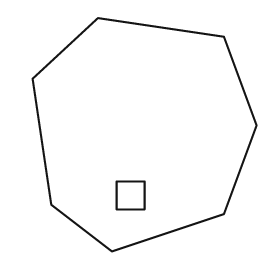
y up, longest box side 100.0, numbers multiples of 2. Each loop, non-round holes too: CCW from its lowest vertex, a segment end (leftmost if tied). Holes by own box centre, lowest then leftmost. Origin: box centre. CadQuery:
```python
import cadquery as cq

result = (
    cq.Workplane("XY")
    .moveTo(-14.0, -50.0)
    .lineTo(34.0, -34.0)
    .lineTo(48.0, 4.0)
    .lineTo(34.0, 42.0)
    .lineTo(-20.0, 50.0)
    .lineTo(-48.0, 24.0)
    .lineTo(-40.0, -30.0)
    .close()
    .moveTo(-12.0, -32.0)
    .lineTo(0.0, -32.0)
    .lineTo(0.0, -20.0)
    .lineTo(-12.0, -20.0)
    .close()
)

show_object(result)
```